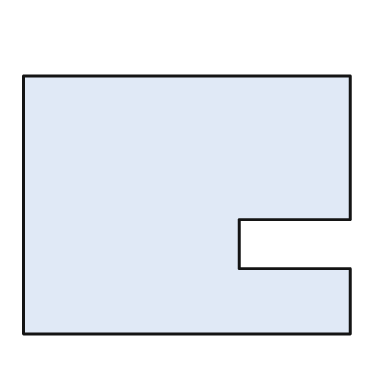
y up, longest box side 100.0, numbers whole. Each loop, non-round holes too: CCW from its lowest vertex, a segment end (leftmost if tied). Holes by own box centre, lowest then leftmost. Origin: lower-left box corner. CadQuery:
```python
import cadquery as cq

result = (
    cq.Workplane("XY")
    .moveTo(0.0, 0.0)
    .lineTo(100.0, 0.0)
    .lineTo(100.0, 20.0)
    .lineTo(66.0, 20.0)
    .lineTo(66.0, 35.0)
    .lineTo(100.0, 35.0)
    .lineTo(100.0, 79.0)
    .lineTo(0.0, 79.0)
    .close()
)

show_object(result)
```